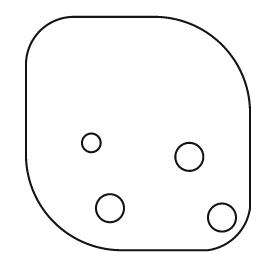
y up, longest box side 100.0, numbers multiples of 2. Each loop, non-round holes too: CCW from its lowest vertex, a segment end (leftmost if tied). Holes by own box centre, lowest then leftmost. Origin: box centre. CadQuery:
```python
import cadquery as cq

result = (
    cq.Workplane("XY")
    .moveTo(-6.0, -50.0)
    .lineTo(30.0, -50.0)
    .threePointArc((42.0, -44.0), (48.0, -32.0))
    .lineTo(48.0, 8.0)
    .threePointArc((36.0, 38.0), (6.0, 50.0))
    .lineTo(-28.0, 50.0)
    .threePointArc((-42.0, 44.0), (-48.0, 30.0))
    .lineTo(-48.0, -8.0)
    .threePointArc((-36.0, -38.0), (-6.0, -50.0))
    .close()
    .moveTo(36.0, -36.0)
    .circle(6.0)
    .moveTo(-12.0, -32.0)
    .circle(6.0)
    .moveTo(22.0, -10.0)
    .circle(6.0)
    .moveTo(-20.0, -4.0)
    .circle(4.0)
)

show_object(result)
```